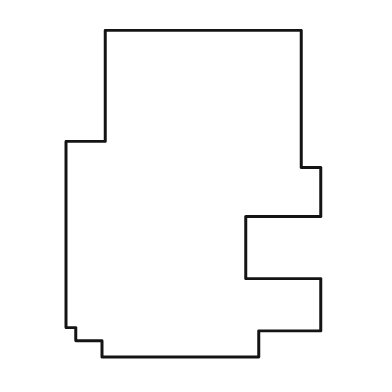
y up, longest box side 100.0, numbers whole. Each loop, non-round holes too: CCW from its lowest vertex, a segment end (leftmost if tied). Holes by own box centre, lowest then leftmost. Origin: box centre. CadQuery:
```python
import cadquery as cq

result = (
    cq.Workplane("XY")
    .moveTo(-28.0, -50.0)
    .lineTo(20.0, -50.0)
    .lineTo(20.0, -42.0)
    .lineTo(39.0, -42.0)
    .lineTo(39.0, -26.0)
    .lineTo(16.0, -26.0)
    .lineTo(16.0, -7.0)
    .lineTo(39.0, -7.0)
    .lineTo(39.0, 8.0)
    .lineTo(33.0, 8.0)
    .lineTo(33.0, 50.0)
    .lineTo(-27.0, 50.0)
    .lineTo(-27.0, 16.0)
    .lineTo(-39.0, 16.0)
    .lineTo(-39.0, -41.0)
    .lineTo(-36.0, -41.0)
    .lineTo(-36.0, -45.0)
    .lineTo(-28.0, -45.0)
    .close()
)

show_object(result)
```